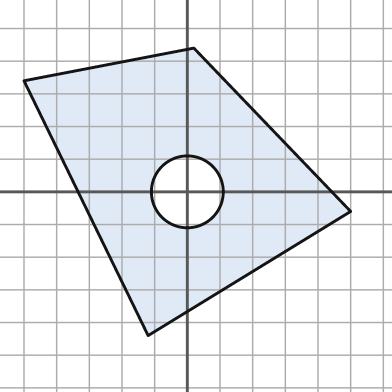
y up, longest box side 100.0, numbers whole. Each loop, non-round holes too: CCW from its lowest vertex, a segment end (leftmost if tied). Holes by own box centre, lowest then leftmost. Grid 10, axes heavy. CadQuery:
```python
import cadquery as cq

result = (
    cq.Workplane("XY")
    .moveTo(-12.0, -44.0)
    .lineTo(50.0, -6.0)
    .lineTo(2.0, 44.0)
    .lineTo(-50.0, 34.0)
    .close()
    .moveTo(0.0, 0.0)
    .circle(11.0)
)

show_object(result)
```